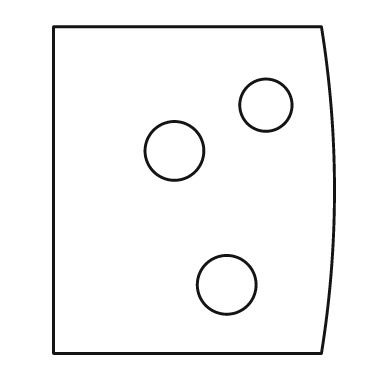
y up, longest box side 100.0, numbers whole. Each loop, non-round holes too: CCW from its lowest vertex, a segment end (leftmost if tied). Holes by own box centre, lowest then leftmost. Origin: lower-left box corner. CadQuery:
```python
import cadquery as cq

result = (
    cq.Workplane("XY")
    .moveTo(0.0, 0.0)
    .lineTo(82.0, 0.0)
    .threePointArc((86.0, 50.0), (82.0, 100.0))
    .lineTo(0.0, 100.0)
    .close()
    .moveTo(53.0, 21.0)
    .circle(9.0)
    .moveTo(37.0, 62.0)
    .circle(9.0)
    .moveTo(65.0, 76.0)
    .circle(8.0)
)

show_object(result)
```